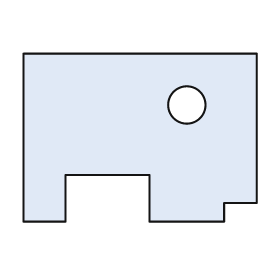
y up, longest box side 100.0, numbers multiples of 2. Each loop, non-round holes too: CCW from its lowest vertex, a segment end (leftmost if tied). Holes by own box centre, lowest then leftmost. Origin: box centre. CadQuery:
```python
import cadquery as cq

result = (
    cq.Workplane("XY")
    .moveTo(-50.0, -36.0)
    .lineTo(-32.0, -36.0)
    .lineTo(-32.0, -16.0)
    .lineTo(4.0, -16.0)
    .lineTo(4.0, -36.0)
    .lineTo(36.0, -36.0)
    .lineTo(36.0, -28.0)
    .lineTo(50.0, -28.0)
    .lineTo(50.0, 36.0)
    .lineTo(-50.0, 36.0)
    .close()
    .moveTo(20.0, 14.0)
    .circle(8.0)
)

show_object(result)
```